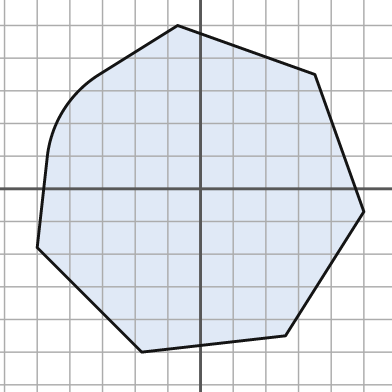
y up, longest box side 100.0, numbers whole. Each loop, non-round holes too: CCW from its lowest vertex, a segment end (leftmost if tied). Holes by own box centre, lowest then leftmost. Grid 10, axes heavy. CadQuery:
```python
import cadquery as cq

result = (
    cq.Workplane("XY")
    .moveTo(-18.0, -50.0)
    .lineTo(26.0, -45.0)
    .lineTo(50.0, -7.0)
    .lineTo(35.0, 35.0)
    .lineTo(-7.0, 50.0)
    .lineTo(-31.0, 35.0)
    .threePointArc((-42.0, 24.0), (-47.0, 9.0))
    .lineTo(-50.0, -18.0)
    .close()
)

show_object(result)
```